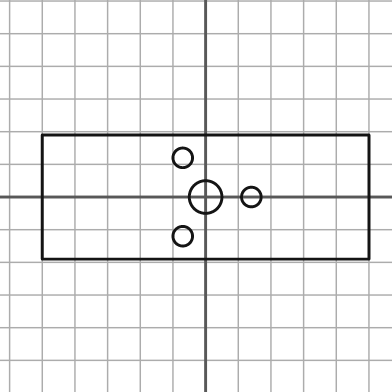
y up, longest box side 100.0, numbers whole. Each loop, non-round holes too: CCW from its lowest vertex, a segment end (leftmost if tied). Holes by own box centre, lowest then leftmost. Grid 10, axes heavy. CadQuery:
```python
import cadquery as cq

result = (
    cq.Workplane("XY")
    .moveTo(-50.0, -19.0)
    .lineTo(50.0, -19.0)
    .lineTo(50.0, 19.0)
    .lineTo(-50.0, 19.0)
    .close()
    .moveTo(-7.0, -12.0)
    .circle(3.0)
    .moveTo(0.0, 0.0)
    .circle(5.0)
    .moveTo(14.0, 0.0)
    .circle(3.0)
    .moveTo(-7.0, 12.0)
    .circle(3.0)
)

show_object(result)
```